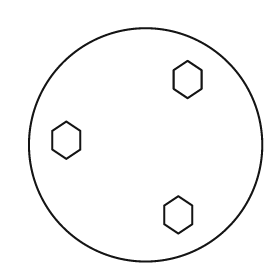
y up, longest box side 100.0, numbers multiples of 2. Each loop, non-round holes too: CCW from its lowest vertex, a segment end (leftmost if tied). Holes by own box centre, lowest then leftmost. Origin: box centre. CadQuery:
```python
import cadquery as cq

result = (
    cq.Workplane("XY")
    .moveTo(0.0, 0.0)
    .circle(50.0)
    .moveTo(14.0, -38.0)
    .lineTo(20.0, -34.0)
    .lineTo(20.0, -26.0)
    .lineTo(14.0, -22.0)
    .lineTo(8.0, -26.0)
    .lineTo(8.0, -34.0)
    .close()
    .moveTo(-34.0, -6.0)
    .lineTo(-28.0, -2.0)
    .lineTo(-28.0, 6.0)
    .lineTo(-34.0, 10.0)
    .lineTo(-40.0, 6.0)
    .lineTo(-40.0, -2.0)
    .close()
    .moveTo(18.0, 20.0)
    .lineTo(24.0, 24.0)
    .lineTo(24.0, 32.0)
    .lineTo(18.0, 36.0)
    .lineTo(12.0, 32.0)
    .lineTo(12.0, 24.0)
    .close()
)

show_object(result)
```